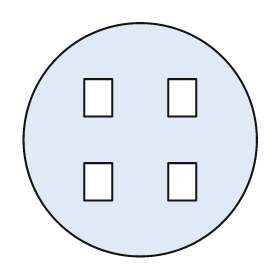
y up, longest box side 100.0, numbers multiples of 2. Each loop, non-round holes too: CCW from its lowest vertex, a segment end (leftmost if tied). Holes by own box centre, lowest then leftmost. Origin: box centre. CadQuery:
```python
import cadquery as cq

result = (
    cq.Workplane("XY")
    .moveTo(0.0, 0.0)
    .circle(50.0)
    .moveTo(-24.0, -26.0)
    .lineTo(-12.0, -26.0)
    .lineTo(-12.0, -10.0)
    .lineTo(-24.0, -10.0)
    .close()
    .moveTo(12.0, -26.0)
    .lineTo(24.0, -26.0)
    .lineTo(24.0, -10.0)
    .lineTo(12.0, -10.0)
    .close()
    .moveTo(-24.0, 10.0)
    .lineTo(-12.0, 10.0)
    .lineTo(-12.0, 26.0)
    .lineTo(-24.0, 26.0)
    .close()
    .moveTo(12.0, 10.0)
    .lineTo(24.0, 10.0)
    .lineTo(24.0, 26.0)
    .lineTo(12.0, 26.0)
    .close()
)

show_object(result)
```